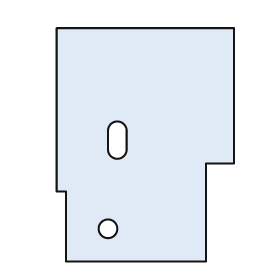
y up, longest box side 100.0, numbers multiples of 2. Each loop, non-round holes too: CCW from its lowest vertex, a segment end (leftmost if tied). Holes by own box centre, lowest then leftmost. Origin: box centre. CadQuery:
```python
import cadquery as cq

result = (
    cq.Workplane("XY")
    .moveTo(-34.0, -50.0)
    .lineTo(26.0, -50.0)
    .lineTo(26.0, -8.0)
    .lineTo(38.0, -8.0)
    .lineTo(38.0, 50.0)
    .lineTo(-38.0, 50.0)
    .lineTo(-38.0, -20.0)
    .lineTo(-34.0, -20.0)
    .close()
    .moveTo(-16.0, -36.0)
    .circle(4.0)
    .moveTo(-16.0, -2.0)
    .threePointArc((-12.0, -6.0), (-8.0, -2.0))
    .lineTo(-8.0, 6.0)
    .threePointArc((-12.0, 10.0), (-16.0, 6.0))
    .close()
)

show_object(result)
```